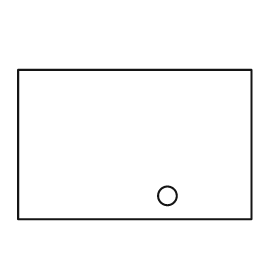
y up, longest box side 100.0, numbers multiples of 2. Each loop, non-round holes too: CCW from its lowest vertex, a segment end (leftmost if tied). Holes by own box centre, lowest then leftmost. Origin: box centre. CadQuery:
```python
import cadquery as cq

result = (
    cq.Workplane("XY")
    .moveTo(-50.0, -32.0)
    .lineTo(50.0, -32.0)
    .lineTo(50.0, 32.0)
    .lineTo(-50.0, 32.0)
    .close()
    .moveTo(14.0, -22.0)
    .circle(4.0)
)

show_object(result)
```